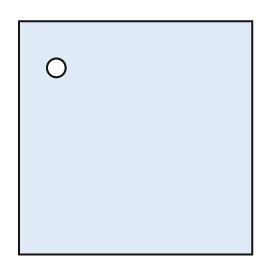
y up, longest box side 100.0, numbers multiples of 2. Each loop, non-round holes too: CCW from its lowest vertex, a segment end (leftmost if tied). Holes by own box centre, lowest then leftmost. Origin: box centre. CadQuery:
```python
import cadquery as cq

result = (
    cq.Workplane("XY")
    .moveTo(-50.0, -50.0)
    .lineTo(50.0, -50.0)
    .lineTo(50.0, 50.0)
    .lineTo(-50.0, 50.0)
    .close()
    .moveTo(-34.0, 30.0)
    .circle(4.0)
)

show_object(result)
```